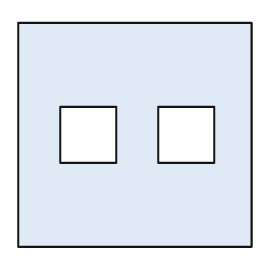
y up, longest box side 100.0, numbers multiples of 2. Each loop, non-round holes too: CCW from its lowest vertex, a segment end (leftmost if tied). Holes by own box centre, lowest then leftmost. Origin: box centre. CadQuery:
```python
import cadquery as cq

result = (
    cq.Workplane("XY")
    .moveTo(-50.0, -48.0)
    .lineTo(50.0, -48.0)
    .lineTo(50.0, 48.0)
    .lineTo(-50.0, 48.0)
    .close()
    .moveTo(-32.0, -12.0)
    .lineTo(-8.0, -12.0)
    .lineTo(-8.0, 12.0)
    .lineTo(-32.0, 12.0)
    .close()
    .moveTo(10.0, -12.0)
    .lineTo(34.0, -12.0)
    .lineTo(34.0, 12.0)
    .lineTo(10.0, 12.0)
    .close()
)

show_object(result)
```